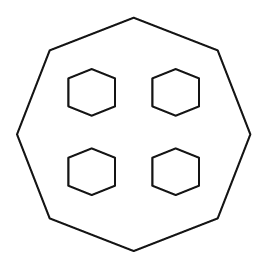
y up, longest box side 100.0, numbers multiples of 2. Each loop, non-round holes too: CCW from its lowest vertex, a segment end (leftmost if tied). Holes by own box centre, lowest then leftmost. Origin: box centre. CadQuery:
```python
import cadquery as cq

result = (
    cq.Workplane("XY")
    .moveTo(0.0, -50.0)
    .lineTo(36.0, -36.0)
    .lineTo(50.0, 0.0)
    .lineTo(36.0, 36.0)
    .lineTo(0.0, 50.0)
    .lineTo(-36.0, 36.0)
    .lineTo(-50.0, 0.0)
    .lineTo(-36.0, -36.0)
    .close()
    .moveTo(-18.0, -26.0)
    .lineTo(-8.0, -22.0)
    .lineTo(-8.0, -10.0)
    .lineTo(-18.0, -6.0)
    .lineTo(-28.0, -10.0)
    .lineTo(-28.0, -22.0)
    .close()
    .moveTo(18.0, -26.0)
    .lineTo(28.0, -22.0)
    .lineTo(28.0, -10.0)
    .lineTo(18.0, -6.0)
    .lineTo(8.0, -10.0)
    .lineTo(8.0, -22.0)
    .close()
    .moveTo(-18.0, 8.0)
    .lineTo(-8.0, 12.0)
    .lineTo(-8.0, 24.0)
    .lineTo(-18.0, 28.0)
    .lineTo(-28.0, 24.0)
    .lineTo(-28.0, 12.0)
    .close()
    .moveTo(18.0, 8.0)
    .lineTo(28.0, 12.0)
    .lineTo(28.0, 24.0)
    .lineTo(18.0, 28.0)
    .lineTo(8.0, 24.0)
    .lineTo(8.0, 12.0)
    .close()
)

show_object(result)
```